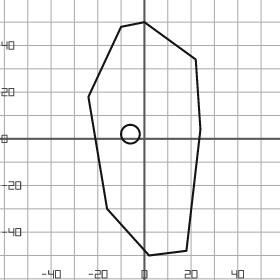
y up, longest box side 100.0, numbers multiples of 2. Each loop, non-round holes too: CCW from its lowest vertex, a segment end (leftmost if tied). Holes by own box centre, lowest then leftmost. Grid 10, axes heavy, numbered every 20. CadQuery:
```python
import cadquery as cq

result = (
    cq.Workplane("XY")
    .moveTo(2.0, -50.0)
    .lineTo(18.0, -48.0)
    .lineTo(24.0, 4.0)
    .lineTo(22.0, 34.0)
    .lineTo(0.0, 50.0)
    .lineTo(-10.0, 48.0)
    .lineTo(-24.0, 18.0)
    .lineTo(-16.0, -30.0)
    .close()
    .moveTo(-6.0, 2.0)
    .circle(4.0)
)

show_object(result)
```